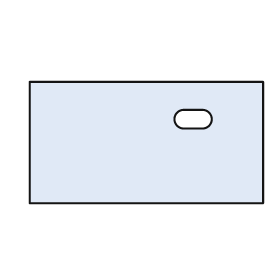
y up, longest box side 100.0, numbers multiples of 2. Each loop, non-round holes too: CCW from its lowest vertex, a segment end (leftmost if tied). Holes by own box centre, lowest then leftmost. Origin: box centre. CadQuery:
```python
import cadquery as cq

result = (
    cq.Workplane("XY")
    .moveTo(-50.0, -26.0)
    .lineTo(50.0, -26.0)
    .lineTo(50.0, 26.0)
    .lineTo(-50.0, 26.0)
    .close()
    .moveTo(16.0, 6.0)
    .lineTo(24.0, 6.0)
    .threePointArc((28.0, 10.0), (24.0, 14.0))
    .lineTo(16.0, 14.0)
    .threePointArc((12.0, 10.0), (16.0, 6.0))
    .close()
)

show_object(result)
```